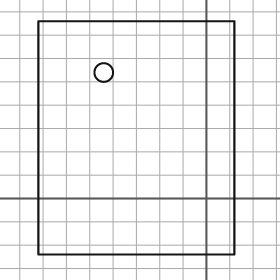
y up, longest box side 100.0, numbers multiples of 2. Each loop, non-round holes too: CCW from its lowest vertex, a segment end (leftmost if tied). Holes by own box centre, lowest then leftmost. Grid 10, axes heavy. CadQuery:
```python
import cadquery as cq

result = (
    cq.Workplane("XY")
    .moveTo(-72.0, -24.0)
    .lineTo(12.0, -24.0)
    .lineTo(12.0, 76.0)
    .lineTo(-72.0, 76.0)
    .close()
    .moveTo(-44.0, 54.0)
    .circle(4.0)
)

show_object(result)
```